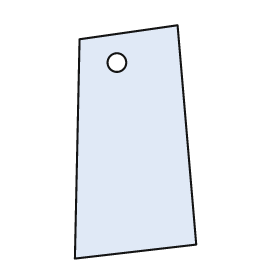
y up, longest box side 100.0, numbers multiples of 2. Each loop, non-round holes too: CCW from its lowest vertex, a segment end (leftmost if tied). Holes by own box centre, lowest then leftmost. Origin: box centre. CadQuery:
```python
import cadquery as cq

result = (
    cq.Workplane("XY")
    .moveTo(-26.0, -50.0)
    .lineTo(26.0, -44.0)
    .lineTo(18.0, 50.0)
    .lineTo(-24.0, 44.0)
    .close()
    .moveTo(-8.0, 34.0)
    .circle(4.0)
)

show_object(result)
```